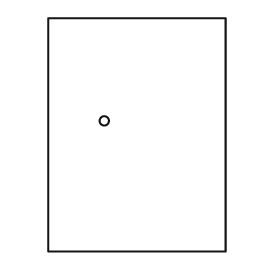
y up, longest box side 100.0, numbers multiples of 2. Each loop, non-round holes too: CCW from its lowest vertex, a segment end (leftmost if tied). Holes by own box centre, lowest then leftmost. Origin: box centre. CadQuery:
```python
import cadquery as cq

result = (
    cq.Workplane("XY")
    .moveTo(-38.0, -50.0)
    .lineTo(38.0, -50.0)
    .lineTo(38.0, 50.0)
    .lineTo(-38.0, 50.0)
    .close()
    .moveTo(-14.0, 6.0)
    .circle(2.0)
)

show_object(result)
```